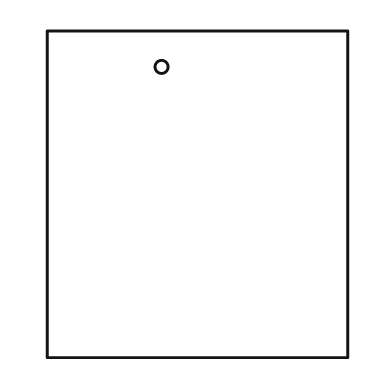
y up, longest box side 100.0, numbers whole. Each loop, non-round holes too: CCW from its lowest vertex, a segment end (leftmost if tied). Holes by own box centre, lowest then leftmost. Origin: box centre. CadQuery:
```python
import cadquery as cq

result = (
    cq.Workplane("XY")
    .moveTo(-46.0, -50.0)
    .lineTo(46.0, -50.0)
    .lineTo(46.0, 50.0)
    .lineTo(-46.0, 50.0)
    .close()
    .moveTo(-11.0, 39.0)
    .circle(2.0)
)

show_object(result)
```